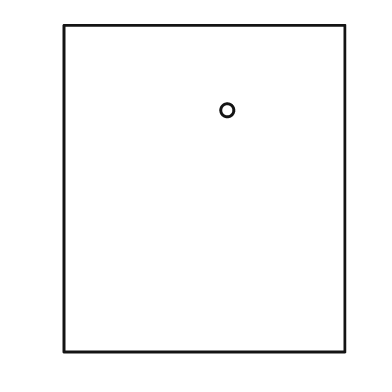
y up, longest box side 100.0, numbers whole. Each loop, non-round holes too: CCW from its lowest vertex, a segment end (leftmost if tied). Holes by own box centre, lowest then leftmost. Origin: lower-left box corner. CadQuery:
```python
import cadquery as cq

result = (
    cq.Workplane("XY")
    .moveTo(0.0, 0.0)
    .lineTo(86.0, 0.0)
    .lineTo(86.0, 100.0)
    .lineTo(0.0, 100.0)
    .close()
    .moveTo(50.0, 74.0)
    .circle(2.0)
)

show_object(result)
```